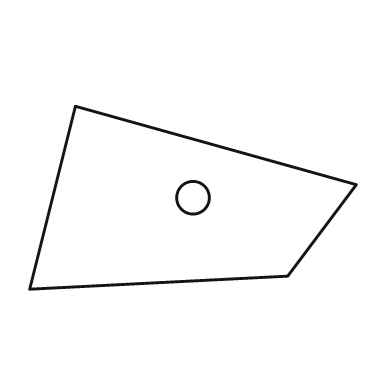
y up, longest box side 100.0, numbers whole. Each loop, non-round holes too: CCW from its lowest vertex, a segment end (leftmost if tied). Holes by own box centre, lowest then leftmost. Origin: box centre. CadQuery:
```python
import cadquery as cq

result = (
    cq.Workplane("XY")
    .moveTo(-50.0, -28.0)
    .lineTo(29.0, -24.0)
    .lineTo(50.0, 4.0)
    .lineTo(-36.0, 28.0)
    .close()
    .moveTo(0.0, 0.0)
    .circle(5.0)
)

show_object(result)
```